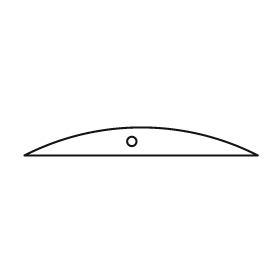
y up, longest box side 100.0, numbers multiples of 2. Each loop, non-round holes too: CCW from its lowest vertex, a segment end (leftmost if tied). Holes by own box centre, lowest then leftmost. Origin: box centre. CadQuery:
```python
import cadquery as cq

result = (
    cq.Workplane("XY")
    .moveTo(-50.0, -6.0)
    .lineTo(50.0, -6.0)
    .threePointArc((0.0, 6.0), (-50.0, -6.0))
    .close()
    .moveTo(-4.0, 0.0)
    .circle(2.0)
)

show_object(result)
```